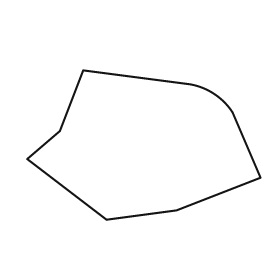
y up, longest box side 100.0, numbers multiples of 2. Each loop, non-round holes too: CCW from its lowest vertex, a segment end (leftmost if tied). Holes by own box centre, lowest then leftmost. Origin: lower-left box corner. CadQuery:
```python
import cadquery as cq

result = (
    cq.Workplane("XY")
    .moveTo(34.0, 0.0)
    .lineTo(64.0, 4.0)
    .lineTo(100.0, 18.0)
    .lineTo(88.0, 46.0)
    .threePointArc((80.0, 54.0), (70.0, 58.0))
    .lineTo(24.0, 64.0)
    .lineTo(14.0, 38.0)
    .lineTo(0.0, 26.0)
    .close()
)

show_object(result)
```